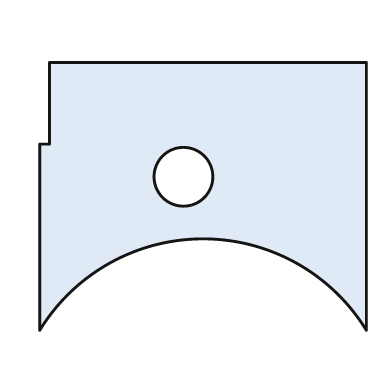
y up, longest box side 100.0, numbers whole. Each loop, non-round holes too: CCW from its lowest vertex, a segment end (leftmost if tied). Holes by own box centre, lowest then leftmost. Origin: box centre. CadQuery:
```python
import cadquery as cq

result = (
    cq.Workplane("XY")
    .moveTo(-50.0, -41.0)
    .threePointArc((0.0, -13.0), (50.0, -41.0))
    .lineTo(50.0, 41.0)
    .lineTo(-47.0, 41.0)
    .lineTo(-47.0, 16.0)
    .lineTo(-50.0, 16.0)
    .close()
    .moveTo(-6.0, 6.0)
    .circle(9.0)
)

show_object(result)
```